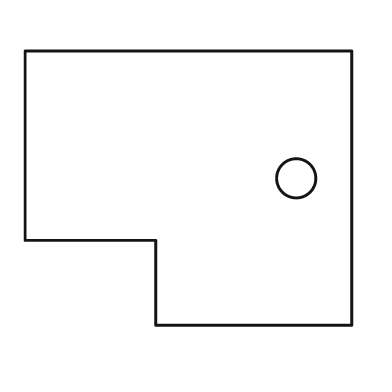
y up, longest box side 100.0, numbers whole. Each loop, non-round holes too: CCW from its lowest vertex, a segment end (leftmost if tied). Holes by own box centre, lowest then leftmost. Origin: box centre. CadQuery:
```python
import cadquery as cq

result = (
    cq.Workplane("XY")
    .moveTo(-10.0, -42.0)
    .lineTo(50.0, -42.0)
    .lineTo(50.0, 42.0)
    .lineTo(-50.0, 42.0)
    .lineTo(-50.0, -16.0)
    .lineTo(-10.0, -16.0)
    .close()
    .moveTo(33.0, 3.0)
    .circle(6.0)
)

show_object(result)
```